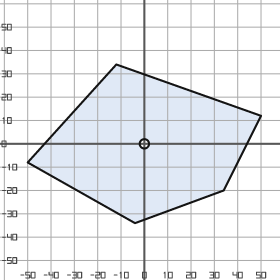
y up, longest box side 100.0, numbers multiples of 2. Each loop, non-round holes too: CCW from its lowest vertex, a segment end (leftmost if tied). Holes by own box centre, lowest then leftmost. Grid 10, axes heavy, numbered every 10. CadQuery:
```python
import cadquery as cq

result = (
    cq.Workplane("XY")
    .moveTo(-4.0, -34.0)
    .lineTo(34.0, -20.0)
    .lineTo(50.0, 12.0)
    .lineTo(-12.0, 34.0)
    .lineTo(-50.0, -8.0)
    .close()
    .moveTo(0.0, 0.0)
    .circle(2.0)
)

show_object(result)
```